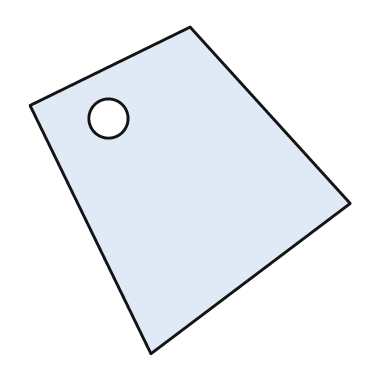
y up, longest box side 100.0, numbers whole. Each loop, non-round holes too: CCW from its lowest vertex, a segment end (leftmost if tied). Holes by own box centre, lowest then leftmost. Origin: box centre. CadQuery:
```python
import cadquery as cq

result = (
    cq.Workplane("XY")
    .moveTo(-12.0, -50.0)
    .lineTo(49.0, -4.0)
    .lineTo(0.0, 50.0)
    .lineTo(-49.0, 26.0)
    .close()
    .moveTo(-25.0, 22.0)
    .circle(6.0)
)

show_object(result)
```